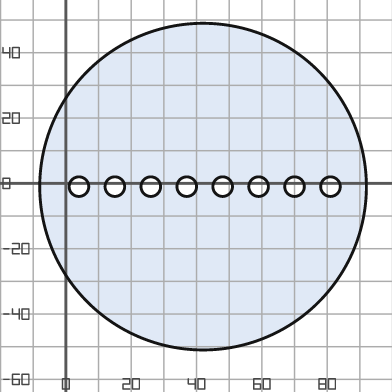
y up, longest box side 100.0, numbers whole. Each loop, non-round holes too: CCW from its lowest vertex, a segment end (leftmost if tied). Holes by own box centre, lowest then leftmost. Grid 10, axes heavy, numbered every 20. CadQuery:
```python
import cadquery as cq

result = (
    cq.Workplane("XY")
    .moveTo(42.0, -1.0)
    .circle(50.0)
    .moveTo(4.0, -1.0)
    .circle(3.0)
    .moveTo(15.0, -1.0)
    .circle(3.0)
    .moveTo(26.0, -1.0)
    .circle(3.0)
    .moveTo(37.0, -1.0)
    .circle(3.0)
    .moveTo(48.0, -1.0)
    .circle(3.0)
    .moveTo(59.0, -1.0)
    .circle(3.0)
    .moveTo(70.0, -1.0)
    .circle(3.0)
    .moveTo(81.0, -1.0)
    .circle(3.0)
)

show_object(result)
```